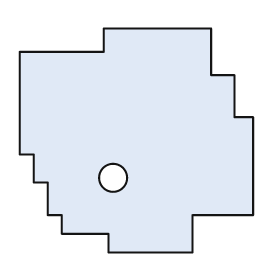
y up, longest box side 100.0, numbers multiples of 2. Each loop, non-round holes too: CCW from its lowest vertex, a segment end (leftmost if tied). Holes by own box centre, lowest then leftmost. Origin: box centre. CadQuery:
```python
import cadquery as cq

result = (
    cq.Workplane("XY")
    .moveTo(-12.0, -48.0)
    .lineTo(24.0, -48.0)
    .lineTo(24.0, -32.0)
    .lineTo(50.0, -32.0)
    .lineTo(50.0, 10.0)
    .lineTo(42.0, 10.0)
    .lineTo(42.0, 28.0)
    .lineTo(32.0, 28.0)
    .lineTo(32.0, 48.0)
    .lineTo(-14.0, 48.0)
    .lineTo(-14.0, 38.0)
    .lineTo(-50.0, 38.0)
    .lineTo(-50.0, -6.0)
    .lineTo(-44.0, -6.0)
    .lineTo(-44.0, -18.0)
    .lineTo(-38.0, -18.0)
    .lineTo(-38.0, -32.0)
    .lineTo(-32.0, -32.0)
    .lineTo(-32.0, -40.0)
    .lineTo(-12.0, -40.0)
    .close()
    .moveTo(-10.0, -16.0)
    .circle(6.0)
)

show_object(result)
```